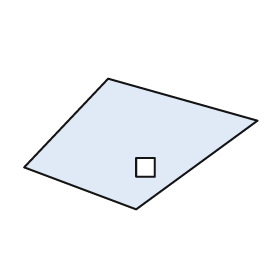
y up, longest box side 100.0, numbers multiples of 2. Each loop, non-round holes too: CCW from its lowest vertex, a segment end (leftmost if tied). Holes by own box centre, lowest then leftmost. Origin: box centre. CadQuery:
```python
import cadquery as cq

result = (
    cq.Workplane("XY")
    .moveTo(-2.0, -28.0)
    .lineTo(50.0, 10.0)
    .lineTo(-14.0, 28.0)
    .lineTo(-50.0, -10.0)
    .close()
    .moveTo(-2.0, -14.0)
    .lineTo(6.0, -14.0)
    .lineTo(6.0, -6.0)
    .lineTo(-2.0, -6.0)
    .close()
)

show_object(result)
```